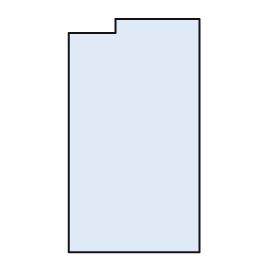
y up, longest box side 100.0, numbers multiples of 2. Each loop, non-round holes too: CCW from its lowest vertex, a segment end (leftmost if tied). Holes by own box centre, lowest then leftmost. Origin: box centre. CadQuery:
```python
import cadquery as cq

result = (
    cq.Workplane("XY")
    .moveTo(-28.0, -50.0)
    .lineTo(28.0, -50.0)
    .lineTo(28.0, 50.0)
    .lineTo(-8.0, 50.0)
    .lineTo(-8.0, 44.0)
    .lineTo(-28.0, 44.0)
    .close()
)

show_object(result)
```